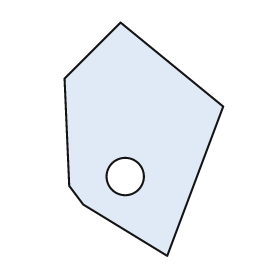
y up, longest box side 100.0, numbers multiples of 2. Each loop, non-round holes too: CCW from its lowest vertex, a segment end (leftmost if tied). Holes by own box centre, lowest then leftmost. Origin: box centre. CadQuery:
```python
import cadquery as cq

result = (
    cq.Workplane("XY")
    .moveTo(10.0, -50.0)
    .lineTo(34.0, 14.0)
    .lineTo(-10.0, 50.0)
    .lineTo(-34.0, 26.0)
    .lineTo(-32.0, -20.0)
    .lineTo(-26.0, -28.0)
    .close()
    .moveTo(-8.0, -16.0)
    .circle(8.0)
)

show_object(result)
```